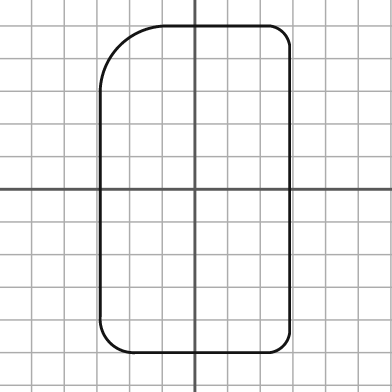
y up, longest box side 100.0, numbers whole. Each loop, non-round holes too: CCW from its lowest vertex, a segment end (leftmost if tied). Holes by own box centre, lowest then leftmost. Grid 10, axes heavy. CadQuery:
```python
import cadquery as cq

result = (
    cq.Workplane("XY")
    .moveTo(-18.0, -50.0)
    .lineTo(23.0, -50.0)
    .threePointArc((27.0, -48.0), (29.0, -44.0))
    .lineTo(29.0, 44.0)
    .threePointArc((27.0, 48.0), (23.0, 50.0))
    .lineTo(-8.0, 50.0)
    .threePointArc((-23.0, 44.0), (-29.0, 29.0))
    .lineTo(-29.0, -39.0)
    .threePointArc((-26.0, -47.0), (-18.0, -50.0))
    .close()
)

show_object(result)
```